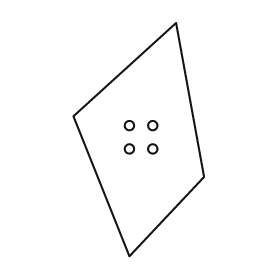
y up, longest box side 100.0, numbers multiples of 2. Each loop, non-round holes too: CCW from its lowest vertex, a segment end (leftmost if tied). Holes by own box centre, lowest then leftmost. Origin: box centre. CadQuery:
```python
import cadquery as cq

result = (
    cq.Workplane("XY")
    .moveTo(-4.0, -50.0)
    .lineTo(28.0, -16.0)
    .lineTo(16.0, 50.0)
    .lineTo(-28.0, 10.0)
    .close()
    .moveTo(-4.0, -4.0)
    .circle(2.0)
    .moveTo(6.0, -4.0)
    .circle(2.0)
    .moveTo(-4.0, 6.0)
    .circle(2.0)
    .moveTo(6.0, 6.0)
    .circle(2.0)
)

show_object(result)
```